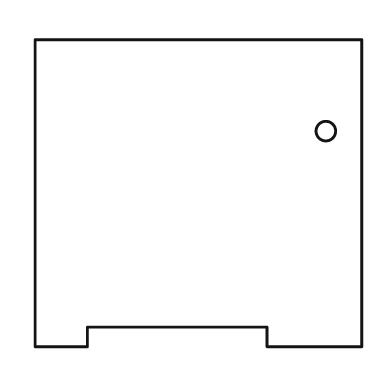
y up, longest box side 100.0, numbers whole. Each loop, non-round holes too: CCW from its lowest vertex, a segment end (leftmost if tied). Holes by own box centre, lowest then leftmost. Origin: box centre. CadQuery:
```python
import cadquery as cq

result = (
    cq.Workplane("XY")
    .moveTo(-50.0, -47.0)
    .lineTo(-34.0, -47.0)
    .lineTo(-34.0, -41.0)
    .lineTo(21.0, -41.0)
    .lineTo(21.0, -47.0)
    .lineTo(50.0, -47.0)
    .lineTo(50.0, 47.0)
    .lineTo(-50.0, 47.0)
    .close()
    .moveTo(39.0, 19.0)
    .circle(3.0)
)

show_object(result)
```